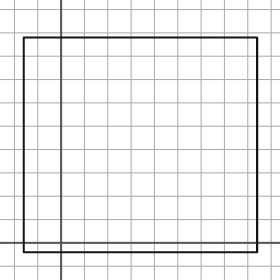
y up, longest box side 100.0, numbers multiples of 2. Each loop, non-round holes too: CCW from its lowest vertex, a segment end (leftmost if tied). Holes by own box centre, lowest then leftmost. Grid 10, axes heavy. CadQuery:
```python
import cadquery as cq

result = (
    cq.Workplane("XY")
    .moveTo(-16.0, -4.0)
    .lineTo(84.0, -4.0)
    .lineTo(84.0, 88.0)
    .lineTo(-16.0, 88.0)
    .close()
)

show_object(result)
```